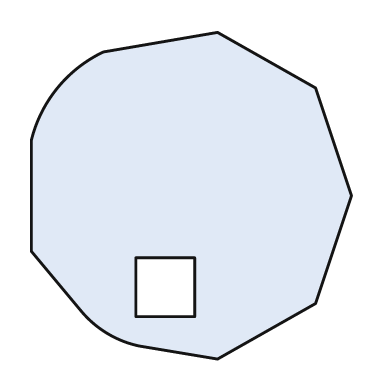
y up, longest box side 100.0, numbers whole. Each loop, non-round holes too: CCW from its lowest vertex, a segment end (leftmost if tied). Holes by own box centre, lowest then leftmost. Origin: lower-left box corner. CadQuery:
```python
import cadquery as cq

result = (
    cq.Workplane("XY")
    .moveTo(57.0, 0.0)
    .lineTo(87.0, 17.0)
    .lineTo(98.0, 50.0)
    .lineTo(87.0, 83.0)
    .lineTo(57.0, 100.0)
    .lineTo(22.0, 94.0)
    .threePointArc((8.0, 83.0), (0.0, 67.0))
    .lineTo(0.0, 33.0)
    .lineTo(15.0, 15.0)
    .threePointArc((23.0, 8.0), (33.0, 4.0))
    .close()
    .moveTo(32.0, 13.0)
    .lineTo(50.0, 13.0)
    .lineTo(50.0, 31.0)
    .lineTo(32.0, 31.0)
    .close()
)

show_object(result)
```